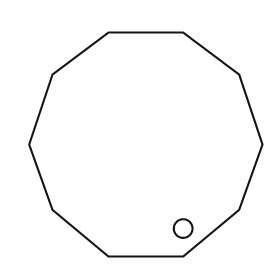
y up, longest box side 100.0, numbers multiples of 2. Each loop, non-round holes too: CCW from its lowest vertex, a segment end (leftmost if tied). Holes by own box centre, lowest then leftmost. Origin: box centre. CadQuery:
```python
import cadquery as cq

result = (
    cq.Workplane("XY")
    .moveTo(-16.0, -48.0)
    .lineTo(16.0, -48.0)
    .lineTo(40.0, -28.0)
    .lineTo(50.0, 0.0)
    .lineTo(40.0, 30.0)
    .lineTo(16.0, 48.0)
    .lineTo(-16.0, 48.0)
    .lineTo(-40.0, 30.0)
    .lineTo(-50.0, 0.0)
    .lineTo(-40.0, -28.0)
    .close()
    .moveTo(16.0, -36.0)
    .circle(4.0)
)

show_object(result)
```